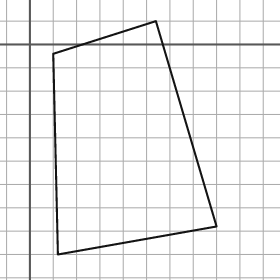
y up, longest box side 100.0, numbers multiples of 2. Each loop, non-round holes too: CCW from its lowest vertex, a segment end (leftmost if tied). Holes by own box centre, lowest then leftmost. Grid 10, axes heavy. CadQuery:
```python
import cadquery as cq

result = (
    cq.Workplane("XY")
    .moveTo(12.0, -90.0)
    .lineTo(80.0, -78.0)
    .lineTo(54.0, 10.0)
    .lineTo(10.0, -4.0)
    .close()
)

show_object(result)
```